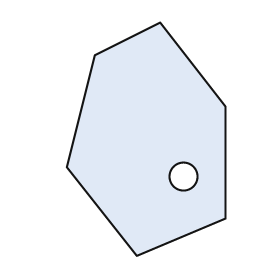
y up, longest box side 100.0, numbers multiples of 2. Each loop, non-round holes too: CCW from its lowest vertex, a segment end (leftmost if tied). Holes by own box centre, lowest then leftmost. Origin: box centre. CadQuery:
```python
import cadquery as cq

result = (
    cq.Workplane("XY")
    .moveTo(-4.0, -50.0)
    .lineTo(34.0, -34.0)
    .lineTo(34.0, 14.0)
    .lineTo(6.0, 50.0)
    .lineTo(-22.0, 36.0)
    .lineTo(-34.0, -12.0)
    .close()
    .moveTo(16.0, -16.0)
    .circle(6.0)
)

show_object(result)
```